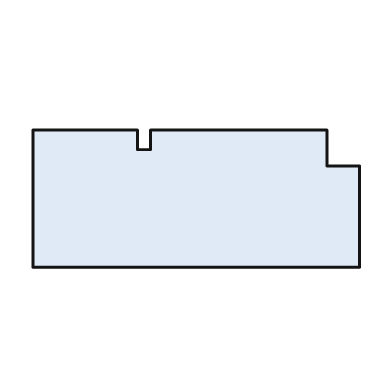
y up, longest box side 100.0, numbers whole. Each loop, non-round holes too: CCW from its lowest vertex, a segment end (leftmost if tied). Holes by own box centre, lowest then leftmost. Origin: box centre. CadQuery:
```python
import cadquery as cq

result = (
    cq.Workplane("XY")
    .moveTo(-50.0, -21.0)
    .lineTo(50.0, -21.0)
    .lineTo(50.0, 10.0)
    .lineTo(40.0, 10.0)
    .lineTo(40.0, 21.0)
    .lineTo(-14.0, 21.0)
    .lineTo(-14.0, 15.0)
    .lineTo(-18.0, 15.0)
    .lineTo(-18.0, 21.0)
    .lineTo(-50.0, 21.0)
    .close()
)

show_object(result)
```